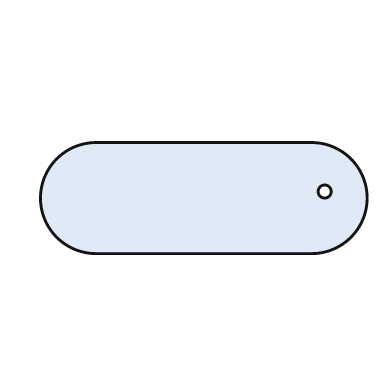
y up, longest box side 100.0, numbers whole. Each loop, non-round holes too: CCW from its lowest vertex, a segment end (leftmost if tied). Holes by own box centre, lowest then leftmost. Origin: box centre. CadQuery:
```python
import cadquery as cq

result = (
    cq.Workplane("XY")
    .moveTo(-33.0, -17.0)
    .lineTo(33.0, -17.0)
    .threePointArc((50.0, 0.0), (33.0, 17.0))
    .lineTo(-33.0, 17.0)
    .threePointArc((-50.0, 0.0), (-33.0, -17.0))
    .close()
    .moveTo(37.0, 2.0)
    .circle(2.0)
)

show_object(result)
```